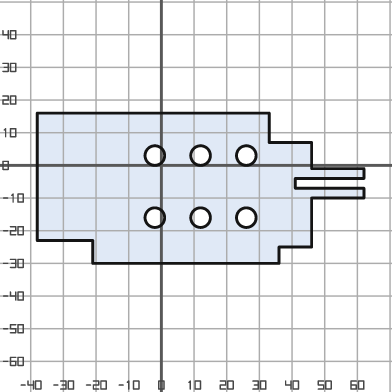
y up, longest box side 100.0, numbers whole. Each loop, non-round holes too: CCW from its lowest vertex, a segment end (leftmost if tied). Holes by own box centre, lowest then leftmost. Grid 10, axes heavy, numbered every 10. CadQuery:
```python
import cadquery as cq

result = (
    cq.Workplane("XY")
    .moveTo(-21.0, -30.0)
    .lineTo(36.0, -30.0)
    .lineTo(36.0, -25.0)
    .lineTo(46.0, -25.0)
    .lineTo(46.0, -10.0)
    .lineTo(62.0, -10.0)
    .lineTo(62.0, -7.0)
    .lineTo(41.0, -7.0)
    .lineTo(41.0, -4.0)
    .lineTo(62.0, -4.0)
    .lineTo(62.0, -1.0)
    .lineTo(46.0, -1.0)
    .lineTo(46.0, 7.0)
    .lineTo(33.0, 7.0)
    .lineTo(33.0, 16.0)
    .lineTo(-38.0, 16.0)
    .lineTo(-38.0, -23.0)
    .lineTo(-21.0, -23.0)
    .close()
    .moveTo(-2.0, -16.0)
    .circle(3.0)
    .moveTo(12.0, -16.0)
    .circle(3.0)
    .moveTo(26.0, -16.0)
    .circle(3.0)
    .moveTo(-2.0, 3.0)
    .circle(3.0)
    .moveTo(12.0, 3.0)
    .circle(3.0)
    .moveTo(26.0, 3.0)
    .circle(3.0)
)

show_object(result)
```